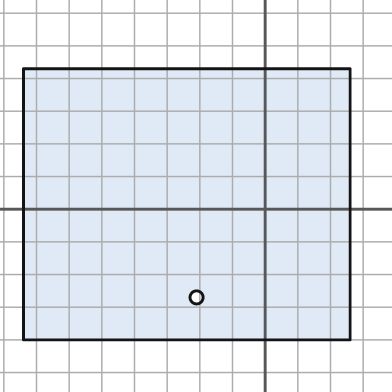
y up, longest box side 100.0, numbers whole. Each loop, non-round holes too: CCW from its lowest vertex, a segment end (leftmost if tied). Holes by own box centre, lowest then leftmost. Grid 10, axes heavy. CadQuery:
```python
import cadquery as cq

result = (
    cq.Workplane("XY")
    .moveTo(-74.0, -40.0)
    .lineTo(26.0, -40.0)
    .lineTo(26.0, 43.0)
    .lineTo(-74.0, 43.0)
    .close()
    .moveTo(-21.0, -27.0)
    .circle(2.0)
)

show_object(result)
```